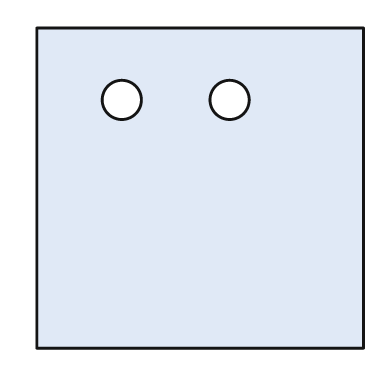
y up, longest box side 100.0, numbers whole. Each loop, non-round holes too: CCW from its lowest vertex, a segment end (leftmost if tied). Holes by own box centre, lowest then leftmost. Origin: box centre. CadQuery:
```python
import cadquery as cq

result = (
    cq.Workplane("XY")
    .moveTo(-50.0, -49.0)
    .lineTo(50.0, -49.0)
    .lineTo(50.0, 49.0)
    .lineTo(-50.0, 49.0)
    .close()
    .moveTo(-24.0, 27.0)
    .circle(6.0)
    .moveTo(9.0, 27.0)
    .circle(6.0)
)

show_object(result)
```